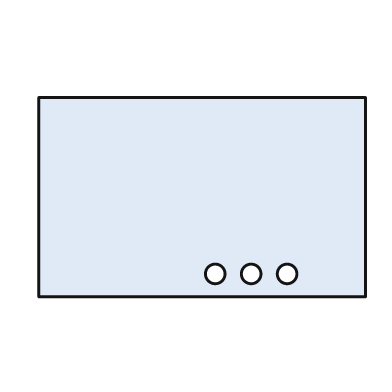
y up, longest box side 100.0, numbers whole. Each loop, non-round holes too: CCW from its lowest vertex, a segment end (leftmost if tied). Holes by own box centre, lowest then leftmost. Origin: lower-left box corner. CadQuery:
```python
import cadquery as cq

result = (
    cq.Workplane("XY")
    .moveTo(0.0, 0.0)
    .lineTo(100.0, 0.0)
    .lineTo(100.0, 61.0)
    .lineTo(0.0, 61.0)
    .close()
    .moveTo(54.0, 7.0)
    .circle(3.0)
    .moveTo(65.0, 7.0)
    .circle(3.0)
    .moveTo(76.0, 7.0)
    .circle(3.0)
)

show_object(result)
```